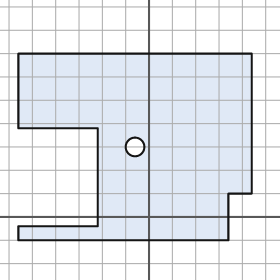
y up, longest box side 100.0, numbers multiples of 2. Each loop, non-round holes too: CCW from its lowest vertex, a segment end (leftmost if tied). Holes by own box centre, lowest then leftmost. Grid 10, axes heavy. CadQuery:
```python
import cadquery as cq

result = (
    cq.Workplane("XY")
    .moveTo(-56.0, -10.0)
    .lineTo(34.0, -10.0)
    .lineTo(34.0, 10.0)
    .lineTo(44.0, 10.0)
    .lineTo(44.0, 70.0)
    .lineTo(-56.0, 70.0)
    .lineTo(-56.0, 38.0)
    .lineTo(-22.0, 38.0)
    .lineTo(-22.0, -4.0)
    .lineTo(-56.0, -4.0)
    .close()
    .moveTo(-6.0, 30.0)
    .circle(4.0)
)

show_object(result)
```